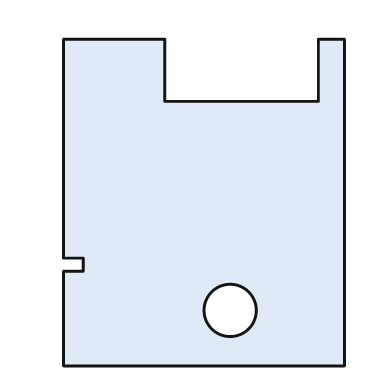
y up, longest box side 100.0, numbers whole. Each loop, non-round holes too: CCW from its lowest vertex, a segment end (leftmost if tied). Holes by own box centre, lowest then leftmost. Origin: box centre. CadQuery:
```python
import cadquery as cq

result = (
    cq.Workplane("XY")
    .moveTo(-43.0, -50.0)
    .lineTo(43.0, -50.0)
    .lineTo(43.0, 50.0)
    .lineTo(35.0, 50.0)
    .lineTo(35.0, 31.0)
    .lineTo(-12.0, 31.0)
    .lineTo(-12.0, 50.0)
    .lineTo(-43.0, 50.0)
    .lineTo(-43.0, -17.0)
    .lineTo(-37.0, -17.0)
    .lineTo(-37.0, -21.0)
    .lineTo(-43.0, -21.0)
    .close()
    .moveTo(8.0, -33.0)
    .circle(8.0)
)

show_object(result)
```